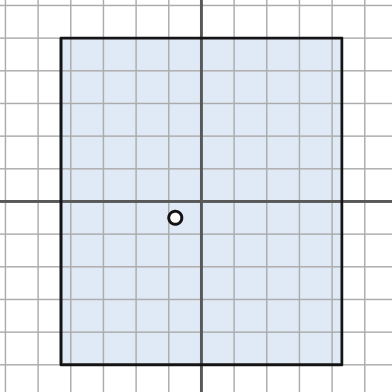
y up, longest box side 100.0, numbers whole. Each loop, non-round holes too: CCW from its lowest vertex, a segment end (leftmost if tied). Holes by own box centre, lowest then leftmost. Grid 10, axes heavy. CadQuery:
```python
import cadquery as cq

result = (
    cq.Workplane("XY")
    .moveTo(-43.0, -50.0)
    .lineTo(43.0, -50.0)
    .lineTo(43.0, 50.0)
    .lineTo(-43.0, 50.0)
    .close()
    .moveTo(-8.0, -5.0)
    .circle(2.0)
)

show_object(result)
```